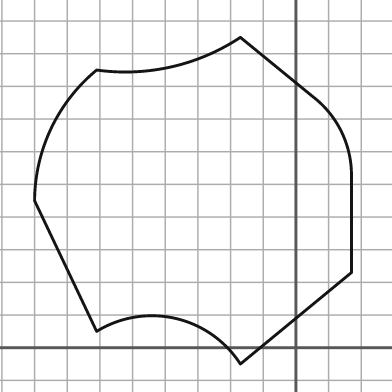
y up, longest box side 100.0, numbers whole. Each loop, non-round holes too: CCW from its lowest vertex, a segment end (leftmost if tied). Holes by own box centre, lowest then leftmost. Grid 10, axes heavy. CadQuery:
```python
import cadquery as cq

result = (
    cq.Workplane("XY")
    .moveTo(-17.0, -5.0)
    .lineTo(17.0, 23.0)
    .lineTo(17.0, 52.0)
    .threePointArc((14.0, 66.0), (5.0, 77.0))
    .lineTo(-17.0, 95.0)
    .threePointArc((-38.0, 86.0), (-61.0, 85.0))
    .threePointArc((-75.0, 67.0), (-80.0, 45.0))
    .lineTo(-61.0, 5.0)
    .threePointArc((-37.0, 9.0), (-17.0, -5.0))
    .close()
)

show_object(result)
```